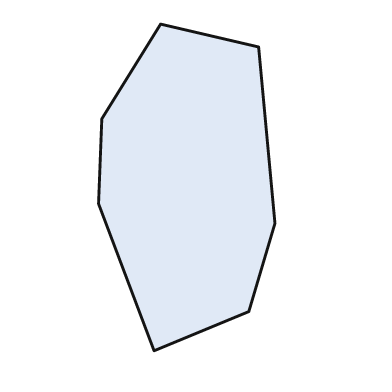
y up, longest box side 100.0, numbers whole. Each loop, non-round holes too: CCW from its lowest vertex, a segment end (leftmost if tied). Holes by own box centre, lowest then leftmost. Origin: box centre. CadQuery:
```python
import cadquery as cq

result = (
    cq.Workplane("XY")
    .moveTo(-10.0, -50.0)
    .lineTo(19.0, -38.0)
    .lineTo(27.0, -11.0)
    .lineTo(22.0, 43.0)
    .lineTo(-8.0, 50.0)
    .lineTo(-26.0, 21.0)
    .lineTo(-27.0, -5.0)
    .close()
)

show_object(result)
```